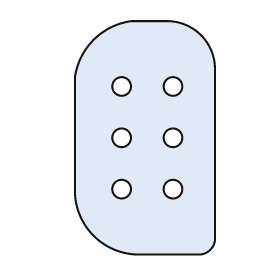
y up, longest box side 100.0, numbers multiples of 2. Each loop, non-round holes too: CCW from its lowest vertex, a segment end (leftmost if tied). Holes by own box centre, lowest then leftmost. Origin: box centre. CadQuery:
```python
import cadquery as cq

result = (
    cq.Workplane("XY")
    .moveTo(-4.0, -50.0)
    .lineTo(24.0, -50.0)
    .threePointArc((28.0, -48.0), (30.0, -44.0))
    .lineTo(30.0, 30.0)
    .threePointArc((24.0, 44.0), (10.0, 50.0))
    .lineTo(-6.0, 50.0)
    .threePointArc((-22.0, 42.0), (-30.0, 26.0))
    .lineTo(-30.0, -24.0)
    .threePointArc((-22.0, -42.0), (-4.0, -50.0))
    .close()
    .moveTo(-10.0, -22.0)
    .circle(4.0)
    .moveTo(12.0, -22.0)
    .circle(4.0)
    .moveTo(-10.0, 0.0)
    .circle(4.0)
    .moveTo(12.0, 0.0)
    .circle(4.0)
    .moveTo(-10.0, 22.0)
    .circle(4.0)
    .moveTo(12.0, 22.0)
    .circle(4.0)
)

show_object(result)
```